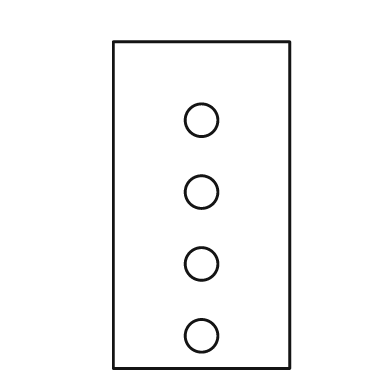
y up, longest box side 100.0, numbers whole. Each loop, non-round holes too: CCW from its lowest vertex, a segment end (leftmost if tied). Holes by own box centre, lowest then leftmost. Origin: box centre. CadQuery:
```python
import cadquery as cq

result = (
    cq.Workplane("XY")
    .moveTo(-27.0, -50.0)
    .lineTo(27.0, -50.0)
    .lineTo(27.0, 50.0)
    .lineTo(-27.0, 50.0)
    .close()
    .moveTo(0.0, -40.0)
    .circle(5.0)
    .moveTo(0.0, -18.0)
    .circle(5.0)
    .moveTo(0.0, 4.0)
    .circle(5.0)
    .moveTo(0.0, 26.0)
    .circle(5.0)
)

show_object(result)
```